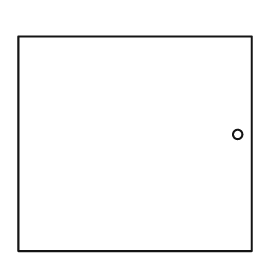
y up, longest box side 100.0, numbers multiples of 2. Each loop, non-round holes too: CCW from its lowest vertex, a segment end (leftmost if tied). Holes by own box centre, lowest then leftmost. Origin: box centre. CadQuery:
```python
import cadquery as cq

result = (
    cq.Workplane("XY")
    .moveTo(-50.0, -46.0)
    .lineTo(50.0, -46.0)
    .lineTo(50.0, 46.0)
    .lineTo(-50.0, 46.0)
    .close()
    .moveTo(44.0, 4.0)
    .circle(2.0)
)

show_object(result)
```